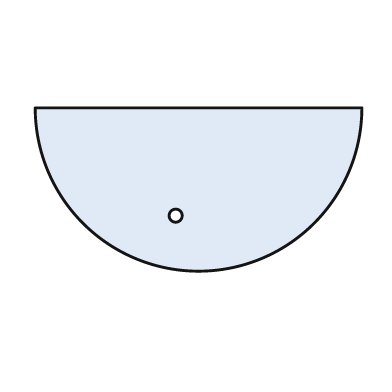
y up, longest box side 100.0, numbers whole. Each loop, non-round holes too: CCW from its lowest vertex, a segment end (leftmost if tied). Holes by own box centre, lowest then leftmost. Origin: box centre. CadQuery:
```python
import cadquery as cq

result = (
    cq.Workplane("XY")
    .moveTo(-50.0, 25.0)
    .threePointArc((0.0, -25.0), (50.0, 25.0))
    .close()
    .moveTo(-7.0, -8.0)
    .circle(2.0)
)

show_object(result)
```